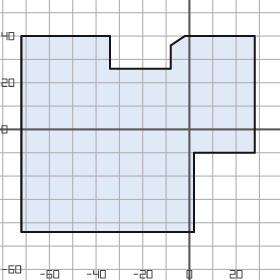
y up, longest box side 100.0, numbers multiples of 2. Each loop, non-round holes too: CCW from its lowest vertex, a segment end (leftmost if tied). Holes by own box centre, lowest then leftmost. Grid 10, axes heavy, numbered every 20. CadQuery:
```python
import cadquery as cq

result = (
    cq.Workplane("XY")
    .moveTo(-72.0, -44.0)
    .lineTo(2.0, -44.0)
    .lineTo(2.0, -10.0)
    .lineTo(28.0, -10.0)
    .lineTo(28.0, 40.0)
    .lineTo(-2.0, 40.0)
    .lineTo(-8.0, 36.0)
    .lineTo(-8.0, 26.0)
    .lineTo(-34.0, 26.0)
    .lineTo(-34.0, 40.0)
    .lineTo(-72.0, 40.0)
    .close()
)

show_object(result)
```